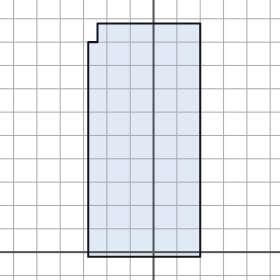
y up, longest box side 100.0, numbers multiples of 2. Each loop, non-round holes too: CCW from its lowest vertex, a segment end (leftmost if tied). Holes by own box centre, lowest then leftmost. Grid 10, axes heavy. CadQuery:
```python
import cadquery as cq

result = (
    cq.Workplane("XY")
    .moveTo(-28.0, -2.0)
    .lineTo(20.0, -2.0)
    .lineTo(20.0, 98.0)
    .lineTo(-24.0, 98.0)
    .lineTo(-24.0, 90.0)
    .lineTo(-28.0, 90.0)
    .close()
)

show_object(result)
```